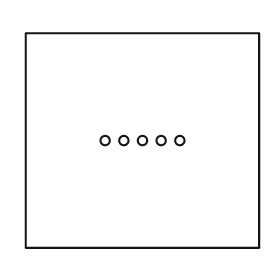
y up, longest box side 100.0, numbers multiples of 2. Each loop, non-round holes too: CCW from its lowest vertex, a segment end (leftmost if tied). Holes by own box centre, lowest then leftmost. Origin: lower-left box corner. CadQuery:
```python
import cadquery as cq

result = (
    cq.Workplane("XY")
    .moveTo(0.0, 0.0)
    .lineTo(100.0, 0.0)
    .lineTo(100.0, 92.0)
    .lineTo(0.0, 92.0)
    .close()
    .moveTo(34.0, 46.0)
    .circle(2.0)
    .moveTo(42.0, 46.0)
    .circle(2.0)
    .moveTo(50.0, 46.0)
    .circle(2.0)
    .moveTo(58.0, 46.0)
    .circle(2.0)
    .moveTo(66.0, 46.0)
    .circle(2.0)
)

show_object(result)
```